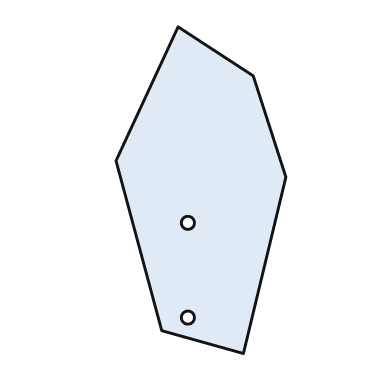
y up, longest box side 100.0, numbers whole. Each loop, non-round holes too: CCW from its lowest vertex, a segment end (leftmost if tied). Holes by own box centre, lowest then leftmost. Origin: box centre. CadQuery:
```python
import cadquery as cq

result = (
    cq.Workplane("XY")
    .moveTo(13.0, -50.0)
    .lineTo(26.0, 4.0)
    .lineTo(16.0, 35.0)
    .lineTo(-7.0, 50.0)
    .lineTo(-26.0, 9.0)
    .lineTo(-12.0, -43.0)
    .close()
    .moveTo(-4.0, -39.0)
    .circle(2.0)
    .moveTo(-4.0, -10.0)
    .circle(2.0)
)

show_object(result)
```